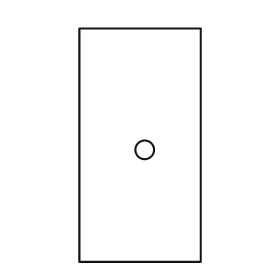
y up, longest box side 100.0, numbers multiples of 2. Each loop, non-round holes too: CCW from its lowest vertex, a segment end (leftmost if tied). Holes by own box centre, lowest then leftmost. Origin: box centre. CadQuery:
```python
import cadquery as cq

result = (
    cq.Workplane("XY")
    .moveTo(-26.0, -50.0)
    .lineTo(26.0, -50.0)
    .lineTo(26.0, 50.0)
    .lineTo(-26.0, 50.0)
    .close()
    .moveTo(2.0, -2.0)
    .circle(4.0)
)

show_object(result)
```